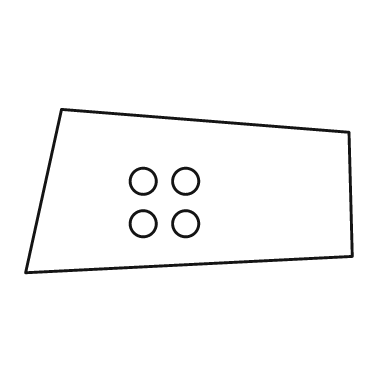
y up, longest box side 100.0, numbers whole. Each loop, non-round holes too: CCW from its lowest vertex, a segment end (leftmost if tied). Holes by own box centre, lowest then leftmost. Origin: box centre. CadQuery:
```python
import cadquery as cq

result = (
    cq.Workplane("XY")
    .moveTo(-50.0, -25.0)
    .lineTo(50.0, -20.0)
    .lineTo(49.0, 18.0)
    .lineTo(-39.0, 25.0)
    .close()
    .moveTo(-14.0, -10.0)
    .circle(4.0)
    .moveTo(-1.0, -10.0)
    .circle(4.0)
    .moveTo(-14.0, 3.0)
    .circle(4.0)
    .moveTo(-1.0, 3.0)
    .circle(4.0)
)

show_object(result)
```